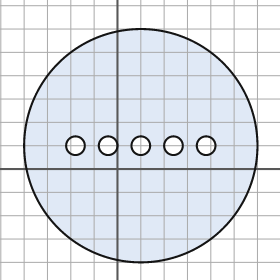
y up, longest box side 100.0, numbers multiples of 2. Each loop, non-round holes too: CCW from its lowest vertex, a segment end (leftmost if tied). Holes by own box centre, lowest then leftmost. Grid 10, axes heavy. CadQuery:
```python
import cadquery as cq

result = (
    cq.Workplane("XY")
    .moveTo(10.0, 10.0)
    .circle(50.0)
    .moveTo(-18.0, 10.0)
    .circle(4.0)
    .moveTo(-4.0, 10.0)
    .circle(4.0)
    .moveTo(10.0, 10.0)
    .circle(4.0)
    .moveTo(24.0, 10.0)
    .circle(4.0)
    .moveTo(38.0, 10.0)
    .circle(4.0)
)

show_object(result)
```